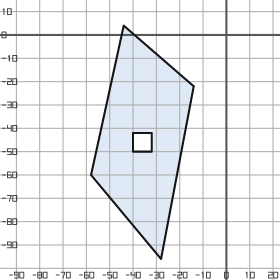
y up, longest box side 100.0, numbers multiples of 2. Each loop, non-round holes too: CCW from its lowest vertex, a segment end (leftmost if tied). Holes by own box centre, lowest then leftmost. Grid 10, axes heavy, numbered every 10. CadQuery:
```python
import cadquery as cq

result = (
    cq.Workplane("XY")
    .moveTo(-28.0, -96.0)
    .lineTo(-14.0, -22.0)
    .lineTo(-44.0, 4.0)
    .lineTo(-58.0, -60.0)
    .close()
    .moveTo(-40.0, -50.0)
    .lineTo(-32.0, -50.0)
    .lineTo(-32.0, -42.0)
    .lineTo(-40.0, -42.0)
    .close()
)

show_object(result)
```